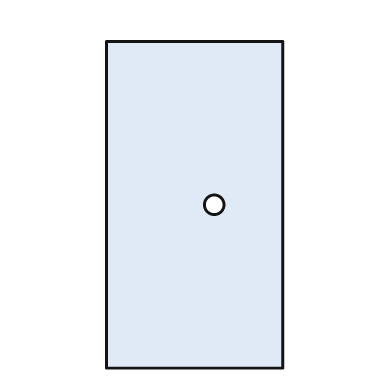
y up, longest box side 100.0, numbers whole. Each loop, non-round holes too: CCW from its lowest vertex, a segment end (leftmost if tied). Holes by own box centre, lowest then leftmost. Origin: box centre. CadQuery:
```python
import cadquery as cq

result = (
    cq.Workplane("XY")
    .moveTo(-27.0, -50.0)
    .lineTo(27.0, -50.0)
    .lineTo(27.0, 50.0)
    .lineTo(-27.0, 50.0)
    .close()
    .moveTo(6.0, 0.0)
    .circle(3.0)
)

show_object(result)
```